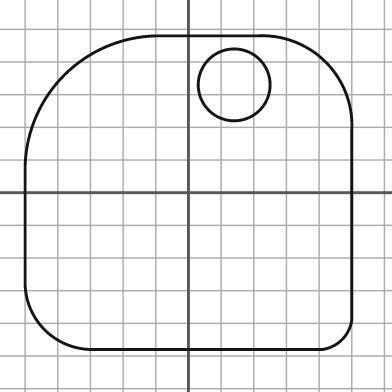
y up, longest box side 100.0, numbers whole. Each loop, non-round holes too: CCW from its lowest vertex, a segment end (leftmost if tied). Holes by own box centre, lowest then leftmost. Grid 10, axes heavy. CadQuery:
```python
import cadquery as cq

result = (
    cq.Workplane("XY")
    .moveTo(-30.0, -48.0)
    .lineTo(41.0, -48.0)
    .threePointArc((47.0, -45.0), (50.0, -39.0))
    .lineTo(50.0, 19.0)
    .threePointArc((42.0, 40.0), (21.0, 48.0))
    .lineTo(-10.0, 48.0)
    .threePointArc((-38.0, 36.0), (-50.0, 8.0))
    .lineTo(-50.0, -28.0)
    .threePointArc((-44.0, -42.0), (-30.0, -48.0))
    .close()
    .moveTo(14.0, 33.0)
    .circle(11.0)
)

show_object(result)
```